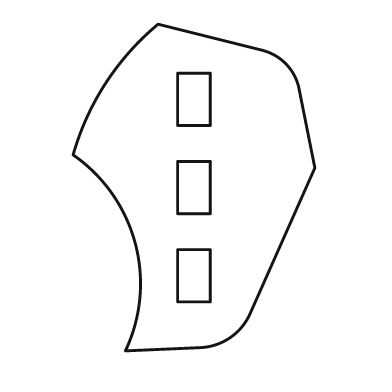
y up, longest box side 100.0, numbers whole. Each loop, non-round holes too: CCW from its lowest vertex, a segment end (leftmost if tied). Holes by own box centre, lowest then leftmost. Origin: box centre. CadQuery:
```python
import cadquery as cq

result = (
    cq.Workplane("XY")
    .moveTo(-21.0, -50.0)
    .lineTo(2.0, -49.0)
    .threePointArc((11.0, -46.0), (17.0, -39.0))
    .lineTo(37.0, 6.0)
    .lineTo(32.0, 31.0)
    .threePointArc((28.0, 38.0), (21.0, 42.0))
    .lineTo(-11.0, 50.0)
    .threePointArc((-27.0, 32.0), (-37.0, 10.0))
    .threePointArc((-18.0, -17.0), (-21.0, -50.0))
    .close()
    .moveTo(-5.0, -35.0)
    .lineTo(5.0, -35.0)
    .lineTo(5.0, -19.0)
    .lineTo(-5.0, -19.0)
    .close()
    .moveTo(-5.0, -8.0)
    .lineTo(5.0, -8.0)
    .lineTo(5.0, 8.0)
    .lineTo(-5.0, 8.0)
    .close()
    .moveTo(-5.0, 19.0)
    .lineTo(5.0, 19.0)
    .lineTo(5.0, 35.0)
    .lineTo(-5.0, 35.0)
    .close()
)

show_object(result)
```